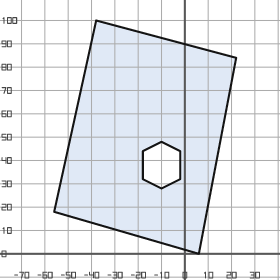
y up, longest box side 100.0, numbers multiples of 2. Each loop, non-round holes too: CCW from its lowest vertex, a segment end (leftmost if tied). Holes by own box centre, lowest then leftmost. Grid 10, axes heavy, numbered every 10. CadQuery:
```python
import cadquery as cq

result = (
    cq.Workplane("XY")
    .moveTo(6.0, 0.0)
    .lineTo(22.0, 84.0)
    .lineTo(-38.0, 100.0)
    .lineTo(-56.0, 18.0)
    .close()
    .moveTo(-10.0, 28.0)
    .lineTo(-2.0, 32.0)
    .lineTo(-2.0, 44.0)
    .lineTo(-10.0, 48.0)
    .lineTo(-18.0, 44.0)
    .lineTo(-18.0, 32.0)
    .close()
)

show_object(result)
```